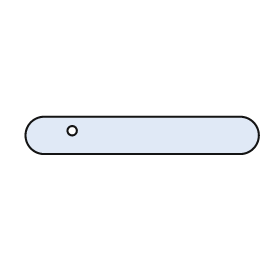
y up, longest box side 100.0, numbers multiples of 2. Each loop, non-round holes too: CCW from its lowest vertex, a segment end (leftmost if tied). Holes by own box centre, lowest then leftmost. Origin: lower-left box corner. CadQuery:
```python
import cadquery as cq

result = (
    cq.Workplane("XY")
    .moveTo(8.0, 0.0)
    .lineTo(92.0, 0.0)
    .threePointArc((100.0, 8.0), (92.0, 16.0))
    .lineTo(8.0, 16.0)
    .threePointArc((0.0, 8.0), (8.0, 0.0))
    .close()
    .moveTo(20.0, 10.0)
    .circle(2.0)
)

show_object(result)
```